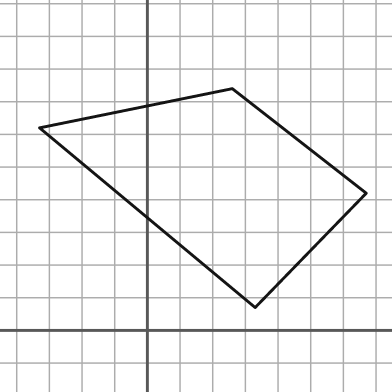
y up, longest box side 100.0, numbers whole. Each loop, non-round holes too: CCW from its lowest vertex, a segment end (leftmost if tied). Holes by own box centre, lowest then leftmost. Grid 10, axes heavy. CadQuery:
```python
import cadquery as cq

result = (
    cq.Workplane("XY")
    .moveTo(33.0, 7.0)
    .lineTo(67.0, 42.0)
    .lineTo(26.0, 74.0)
    .lineTo(-33.0, 62.0)
    .close()
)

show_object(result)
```